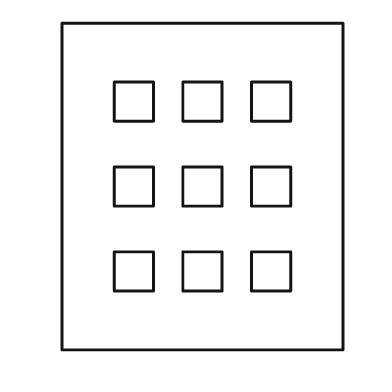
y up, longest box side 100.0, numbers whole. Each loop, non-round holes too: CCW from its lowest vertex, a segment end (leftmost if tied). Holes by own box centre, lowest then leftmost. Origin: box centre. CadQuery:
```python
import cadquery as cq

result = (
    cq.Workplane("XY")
    .moveTo(-43.0, -50.0)
    .lineTo(43.0, -50.0)
    .lineTo(43.0, 50.0)
    .lineTo(-43.0, 50.0)
    .close()
    .moveTo(-27.0, -32.0)
    .lineTo(-15.0, -32.0)
    .lineTo(-15.0, -20.0)
    .lineTo(-27.0, -20.0)
    .close()
    .moveTo(-6.0, -32.0)
    .lineTo(6.0, -32.0)
    .lineTo(6.0, -20.0)
    .lineTo(-6.0, -20.0)
    .close()
    .moveTo(15.0, -32.0)
    .lineTo(27.0, -32.0)
    .lineTo(27.0, -20.0)
    .lineTo(15.0, -20.0)
    .close()
    .moveTo(-27.0, -6.0)
    .lineTo(-15.0, -6.0)
    .lineTo(-15.0, 6.0)
    .lineTo(-27.0, 6.0)
    .close()
    .moveTo(-6.0, -6.0)
    .lineTo(6.0, -6.0)
    .lineTo(6.0, 6.0)
    .lineTo(-6.0, 6.0)
    .close()
    .moveTo(15.0, -6.0)
    .lineTo(27.0, -6.0)
    .lineTo(27.0, 6.0)
    .lineTo(15.0, 6.0)
    .close()
    .moveTo(-27.0, 20.0)
    .lineTo(-15.0, 20.0)
    .lineTo(-15.0, 32.0)
    .lineTo(-27.0, 32.0)
    .close()
    .moveTo(-6.0, 20.0)
    .lineTo(6.0, 20.0)
    .lineTo(6.0, 32.0)
    .lineTo(-6.0, 32.0)
    .close()
    .moveTo(15.0, 20.0)
    .lineTo(27.0, 20.0)
    .lineTo(27.0, 32.0)
    .lineTo(15.0, 32.0)
    .close()
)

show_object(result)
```